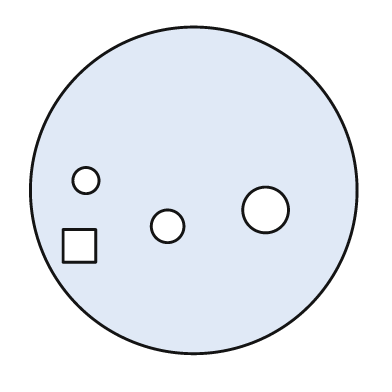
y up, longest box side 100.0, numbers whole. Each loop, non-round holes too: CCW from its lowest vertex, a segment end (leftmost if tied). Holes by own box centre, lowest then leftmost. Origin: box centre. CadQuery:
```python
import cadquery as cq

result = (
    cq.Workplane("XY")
    .moveTo(0.0, 0.0)
    .circle(50.0)
    .moveTo(-40.0, -22.0)
    .lineTo(-30.0, -22.0)
    .lineTo(-30.0, -12.0)
    .lineTo(-40.0, -12.0)
    .close()
    .moveTo(-8.0, -11.0)
    .circle(5.0)
    .moveTo(22.0, -6.0)
    .circle(7.0)
    .moveTo(-33.0, 3.0)
    .circle(4.0)
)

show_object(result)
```